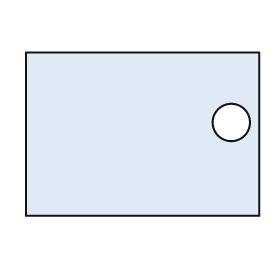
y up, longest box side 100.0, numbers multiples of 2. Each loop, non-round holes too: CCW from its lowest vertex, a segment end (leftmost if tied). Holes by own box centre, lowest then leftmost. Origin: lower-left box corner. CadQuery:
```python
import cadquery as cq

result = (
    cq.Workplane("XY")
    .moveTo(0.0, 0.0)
    .lineTo(100.0, 0.0)
    .lineTo(100.0, 70.0)
    .lineTo(0.0, 70.0)
    .close()
    .moveTo(88.0, 40.0)
    .circle(8.0)
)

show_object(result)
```